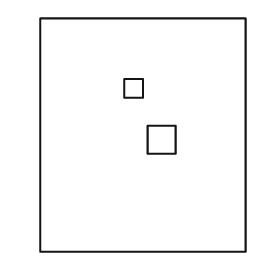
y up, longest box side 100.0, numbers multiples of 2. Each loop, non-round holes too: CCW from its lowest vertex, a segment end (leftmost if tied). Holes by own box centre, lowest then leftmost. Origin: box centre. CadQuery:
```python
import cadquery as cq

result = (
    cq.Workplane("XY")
    .moveTo(-44.0, -50.0)
    .lineTo(44.0, -50.0)
    .lineTo(44.0, 50.0)
    .lineTo(-44.0, 50.0)
    .close()
    .moveTo(2.0, -8.0)
    .lineTo(14.0, -8.0)
    .lineTo(14.0, 4.0)
    .lineTo(2.0, 4.0)
    .close()
    .moveTo(-8.0, 16.0)
    .lineTo(0.0, 16.0)
    .lineTo(0.0, 24.0)
    .lineTo(-8.0, 24.0)
    .close()
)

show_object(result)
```